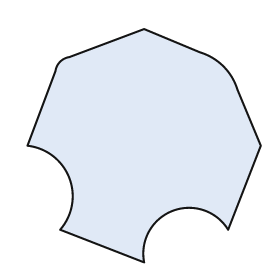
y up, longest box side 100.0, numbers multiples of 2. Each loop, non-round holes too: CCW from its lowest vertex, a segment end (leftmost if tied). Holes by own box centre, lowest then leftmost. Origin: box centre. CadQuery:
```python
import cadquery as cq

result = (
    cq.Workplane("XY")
    .moveTo(0.0, -50.0)
    .threePointArc((12.0, -28.0), (36.0, -36.0))
    .lineTo(50.0, 0.0)
    .lineTo(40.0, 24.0)
    .threePointArc((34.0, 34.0), (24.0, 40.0))
    .lineTo(0.0, 50.0)
    .lineTo(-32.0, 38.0)
    .threePointArc((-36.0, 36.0), (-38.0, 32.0))
    .lineTo(-50.0, 0.0)
    .threePointArc((-32.0, -14.0), (-36.0, -36.0))
    .close()
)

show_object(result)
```